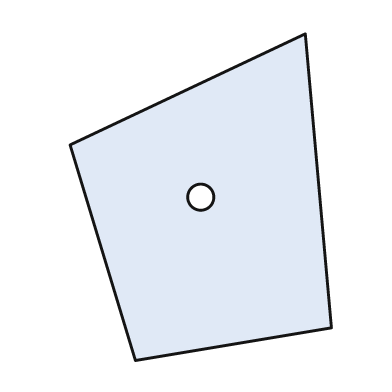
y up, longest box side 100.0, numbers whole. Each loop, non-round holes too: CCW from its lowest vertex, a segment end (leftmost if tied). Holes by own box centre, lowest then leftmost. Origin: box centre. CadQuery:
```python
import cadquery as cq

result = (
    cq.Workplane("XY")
    .moveTo(-20.0, -50.0)
    .lineTo(40.0, -40.0)
    .lineTo(32.0, 50.0)
    .lineTo(-40.0, 16.0)
    .close()
    .moveTo(0.0, 0.0)
    .circle(4.0)
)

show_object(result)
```